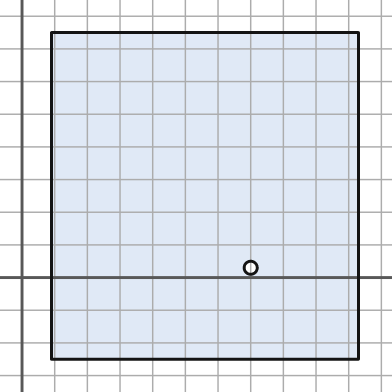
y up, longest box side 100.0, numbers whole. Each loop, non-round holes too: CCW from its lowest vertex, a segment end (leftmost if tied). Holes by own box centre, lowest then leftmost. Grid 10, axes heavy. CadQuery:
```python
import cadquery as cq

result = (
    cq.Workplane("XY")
    .moveTo(9.0, -25.0)
    .lineTo(103.0, -25.0)
    .lineTo(103.0, 75.0)
    .lineTo(9.0, 75.0)
    .close()
    .moveTo(70.0, 3.0)
    .circle(2.0)
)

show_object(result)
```